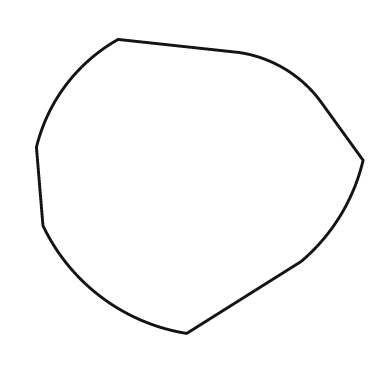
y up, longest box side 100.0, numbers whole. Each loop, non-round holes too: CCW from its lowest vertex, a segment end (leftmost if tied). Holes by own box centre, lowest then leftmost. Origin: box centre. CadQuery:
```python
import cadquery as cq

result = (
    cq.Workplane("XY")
    .moveTo(-4.0, -45.0)
    .lineTo(31.0, -23.0)
    .threePointArc((43.0, -9.0), (50.0, 8.0))
    .lineTo(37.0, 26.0)
    .threePointArc((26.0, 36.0), (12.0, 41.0))
    .lineTo(-25.0, 45.0)
    .threePointArc((-41.0, 31.0), (-50.0, 12.0))
    .lineTo(-48.0, -12.0)
    .threePointArc((-30.0, -34.0), (-4.0, -45.0))
    .close()
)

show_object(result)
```